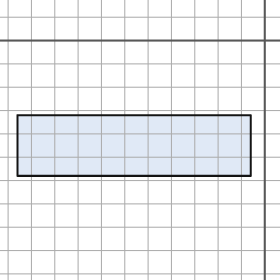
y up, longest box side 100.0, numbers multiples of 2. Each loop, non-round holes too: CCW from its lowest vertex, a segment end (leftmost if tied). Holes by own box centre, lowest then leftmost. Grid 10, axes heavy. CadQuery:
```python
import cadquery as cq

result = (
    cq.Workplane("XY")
    .moveTo(-106.0, -58.0)
    .lineTo(-6.0, -58.0)
    .lineTo(-6.0, -32.0)
    .lineTo(-106.0, -32.0)
    .close()
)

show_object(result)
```